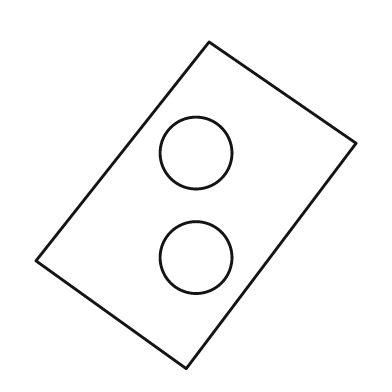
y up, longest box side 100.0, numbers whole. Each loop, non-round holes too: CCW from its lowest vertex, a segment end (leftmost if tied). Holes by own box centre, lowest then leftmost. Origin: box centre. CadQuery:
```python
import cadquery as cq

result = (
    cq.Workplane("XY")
    .moveTo(-3.0, -50.0)
    .lineTo(49.0, 19.0)
    .lineTo(4.0, 50.0)
    .lineTo(-49.0, -17.0)
    .close()
    .moveTo(0.0, -16.0)
    .circle(11.0)
    .moveTo(0.0, 16.0)
    .circle(11.0)
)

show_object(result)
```